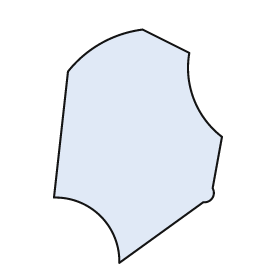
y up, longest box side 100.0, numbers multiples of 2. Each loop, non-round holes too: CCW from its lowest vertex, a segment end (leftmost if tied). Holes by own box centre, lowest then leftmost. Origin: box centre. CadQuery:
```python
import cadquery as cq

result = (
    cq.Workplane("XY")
    .moveTo(-8.0, -50.0)
    .lineTo(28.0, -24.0)
    .threePointArc((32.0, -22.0), (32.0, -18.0))
    .lineTo(36.0, 4.0)
    .threePointArc((24.0, 20.0), (22.0, 40.0))
    .lineTo(2.0, 50.0)
    .threePointArc((-16.0, 44.0), (-30.0, 32.0))
    .lineTo(-36.0, -22.0)
    .threePointArc((-16.0, -30.0), (-8.0, -50.0))
    .close()
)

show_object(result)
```